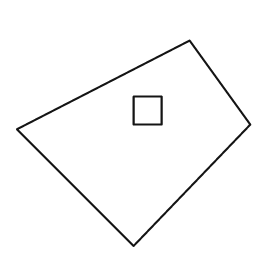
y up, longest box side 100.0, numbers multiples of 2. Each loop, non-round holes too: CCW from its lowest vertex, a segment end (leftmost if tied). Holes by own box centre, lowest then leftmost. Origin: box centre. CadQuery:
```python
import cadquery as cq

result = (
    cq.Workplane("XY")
    .moveTo(0.0, -44.0)
    .lineTo(50.0, 8.0)
    .lineTo(24.0, 44.0)
    .lineTo(-50.0, 6.0)
    .close()
    .moveTo(0.0, 8.0)
    .lineTo(12.0, 8.0)
    .lineTo(12.0, 20.0)
    .lineTo(0.0, 20.0)
    .close()
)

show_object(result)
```